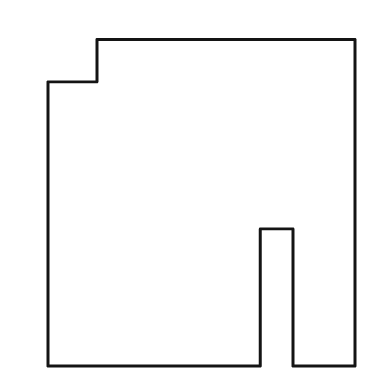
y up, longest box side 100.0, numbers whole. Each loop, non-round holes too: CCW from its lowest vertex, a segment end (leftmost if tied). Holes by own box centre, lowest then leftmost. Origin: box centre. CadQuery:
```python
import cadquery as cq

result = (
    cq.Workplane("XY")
    .moveTo(-47.0, -50.0)
    .lineTo(18.0, -50.0)
    .lineTo(18.0, -8.0)
    .lineTo(28.0, -8.0)
    .lineTo(28.0, -50.0)
    .lineTo(47.0, -50.0)
    .lineTo(47.0, 50.0)
    .lineTo(-32.0, 50.0)
    .lineTo(-32.0, 37.0)
    .lineTo(-47.0, 37.0)
    .close()
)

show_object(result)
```